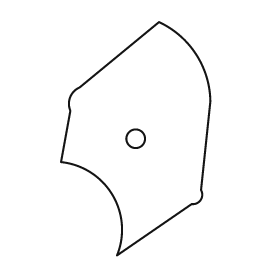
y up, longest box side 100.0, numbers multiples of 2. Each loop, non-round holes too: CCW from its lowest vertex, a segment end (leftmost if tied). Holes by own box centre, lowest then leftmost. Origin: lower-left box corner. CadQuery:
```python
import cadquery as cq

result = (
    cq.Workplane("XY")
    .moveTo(24.0, 0.0)
    .lineTo(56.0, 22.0)
    .threePointArc((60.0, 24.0), (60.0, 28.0))
    .lineTo(64.0, 66.0)
    .threePointArc((58.0, 86.0), (42.0, 100.0))
    .lineTo(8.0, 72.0)
    .threePointArc((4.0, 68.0), (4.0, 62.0))
    .lineTo(0.0, 40.0)
    .threePointArc((22.0, 26.0), (24.0, 0.0))
    .close()
    .moveTo(32.0, 50.0)
    .circle(4.0)
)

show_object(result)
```